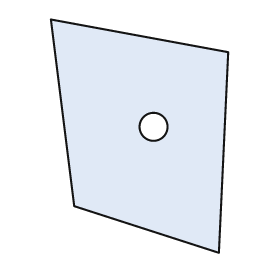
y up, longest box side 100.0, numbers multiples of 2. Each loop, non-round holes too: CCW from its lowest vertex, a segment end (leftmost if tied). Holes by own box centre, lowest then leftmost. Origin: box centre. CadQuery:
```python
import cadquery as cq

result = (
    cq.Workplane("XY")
    .moveTo(34.0, -50.0)
    .lineTo(38.0, 36.0)
    .lineTo(-38.0, 50.0)
    .lineTo(-28.0, -30.0)
    .close()
    .moveTo(6.0, 4.0)
    .circle(6.0)
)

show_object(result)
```